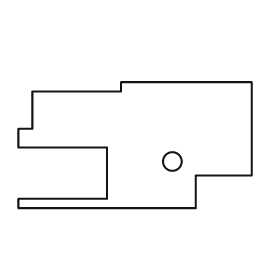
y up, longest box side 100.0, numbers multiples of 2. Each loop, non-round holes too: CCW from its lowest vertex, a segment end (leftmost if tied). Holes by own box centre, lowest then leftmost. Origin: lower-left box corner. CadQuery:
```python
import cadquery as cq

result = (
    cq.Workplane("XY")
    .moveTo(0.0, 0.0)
    .lineTo(76.0, 0.0)
    .lineTo(76.0, 14.0)
    .lineTo(100.0, 14.0)
    .lineTo(100.0, 54.0)
    .lineTo(44.0, 54.0)
    .lineTo(44.0, 50.0)
    .lineTo(6.0, 50.0)
    .lineTo(6.0, 34.0)
    .lineTo(0.0, 34.0)
    .lineTo(0.0, 26.0)
    .lineTo(38.0, 26.0)
    .lineTo(38.0, 4.0)
    .lineTo(0.0, 4.0)
    .close()
    .moveTo(66.0, 20.0)
    .circle(4.0)
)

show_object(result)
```